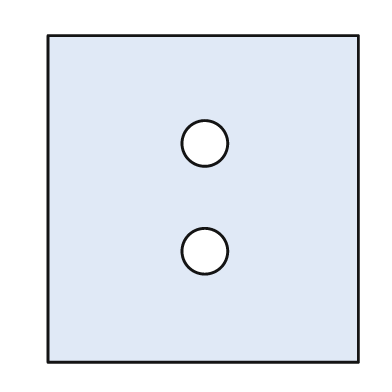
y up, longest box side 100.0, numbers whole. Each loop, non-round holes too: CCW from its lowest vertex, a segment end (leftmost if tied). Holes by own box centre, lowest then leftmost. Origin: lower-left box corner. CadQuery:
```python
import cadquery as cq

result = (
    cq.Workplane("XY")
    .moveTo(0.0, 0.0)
    .lineTo(95.0, 0.0)
    .lineTo(95.0, 100.0)
    .lineTo(0.0, 100.0)
    .close()
    .moveTo(48.0, 34.0)
    .circle(7.0)
    .moveTo(48.0, 67.0)
    .circle(7.0)
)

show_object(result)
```